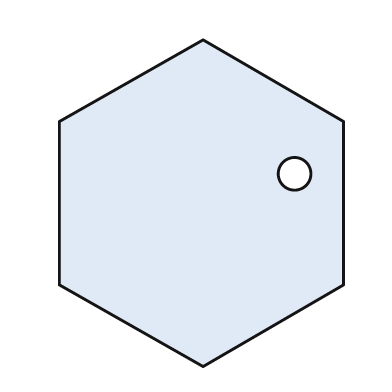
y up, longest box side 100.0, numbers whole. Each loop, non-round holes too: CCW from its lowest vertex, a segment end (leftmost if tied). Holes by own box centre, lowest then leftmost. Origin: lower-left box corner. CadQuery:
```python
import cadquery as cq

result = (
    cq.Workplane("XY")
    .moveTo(44.0, 0.0)
    .lineTo(87.0, 25.0)
    .lineTo(87.0, 75.0)
    .lineTo(44.0, 100.0)
    .lineTo(0.0, 75.0)
    .lineTo(0.0, 25.0)
    .close()
    .moveTo(72.0, 59.0)
    .circle(5.0)
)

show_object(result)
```